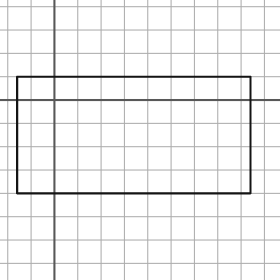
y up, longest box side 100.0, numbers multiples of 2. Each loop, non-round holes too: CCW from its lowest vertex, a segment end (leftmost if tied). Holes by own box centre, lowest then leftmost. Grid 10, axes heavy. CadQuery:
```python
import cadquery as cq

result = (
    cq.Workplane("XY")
    .moveTo(-16.0, -40.0)
    .lineTo(84.0, -40.0)
    .lineTo(84.0, 10.0)
    .lineTo(-16.0, 10.0)
    .close()
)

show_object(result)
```